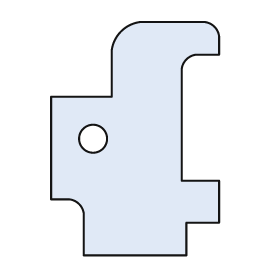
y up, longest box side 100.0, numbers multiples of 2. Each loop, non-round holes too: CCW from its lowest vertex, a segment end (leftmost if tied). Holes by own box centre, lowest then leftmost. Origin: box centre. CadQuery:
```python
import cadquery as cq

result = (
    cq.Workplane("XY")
    .moveTo(-22.0, -50.0)
    .lineTo(22.0, -50.0)
    .lineTo(22.0, -36.0)
    .lineTo(36.0, -36.0)
    .lineTo(36.0, -18.0)
    .lineTo(20.0, -18.0)
    .lineTo(20.0, 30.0)
    .threePointArc((22.0, 34.0), (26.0, 36.0))
    .lineTo(36.0, 36.0)
    .lineTo(36.0, 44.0)
    .threePointArc((34.0, 48.0), (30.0, 50.0))
    .lineTo(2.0, 50.0)
    .threePointArc((-6.0, 46.0), (-10.0, 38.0))
    .lineTo(-10.0, 18.0)
    .lineTo(-36.0, 18.0)
    .lineTo(-36.0, -26.0)
    .lineTo(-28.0, -26.0)
    .threePointArc((-24.0, -28.0), (-22.0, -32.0))
    .close()
    .moveTo(-18.0, 0.0)
    .circle(6.0)
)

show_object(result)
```